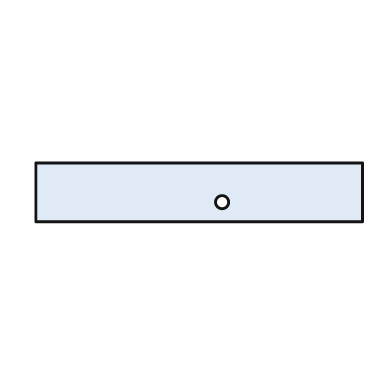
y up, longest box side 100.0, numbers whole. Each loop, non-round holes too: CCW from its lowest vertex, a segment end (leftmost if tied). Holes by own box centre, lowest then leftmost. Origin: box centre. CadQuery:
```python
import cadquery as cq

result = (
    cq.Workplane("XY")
    .moveTo(-50.0, -9.0)
    .lineTo(50.0, -9.0)
    .lineTo(50.0, 9.0)
    .lineTo(-50.0, 9.0)
    .close()
    .moveTo(7.0, -3.0)
    .circle(2.0)
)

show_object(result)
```